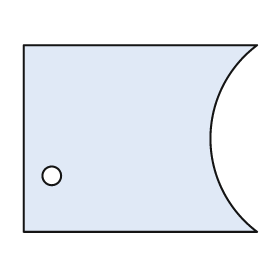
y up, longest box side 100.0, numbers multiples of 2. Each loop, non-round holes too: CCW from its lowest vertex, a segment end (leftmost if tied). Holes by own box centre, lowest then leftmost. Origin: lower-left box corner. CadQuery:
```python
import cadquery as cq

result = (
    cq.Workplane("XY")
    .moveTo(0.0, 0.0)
    .lineTo(100.0, 0.0)
    .threePointArc((80.0, 40.0), (100.0, 80.0))
    .lineTo(0.0, 80.0)
    .close()
    .moveTo(12.0, 24.0)
    .circle(4.0)
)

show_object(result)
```